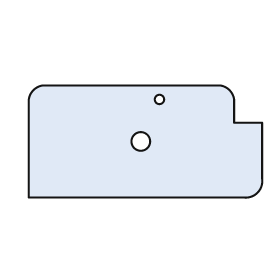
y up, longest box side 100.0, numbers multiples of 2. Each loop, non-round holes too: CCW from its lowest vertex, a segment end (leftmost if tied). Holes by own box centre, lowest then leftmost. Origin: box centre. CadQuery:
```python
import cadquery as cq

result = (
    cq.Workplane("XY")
    .moveTo(-50.0, -24.0)
    .lineTo(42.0, -24.0)
    .threePointArc((48.0, -22.0), (50.0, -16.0))
    .lineTo(50.0, 8.0)
    .lineTo(38.0, 8.0)
    .lineTo(38.0, 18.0)
    .threePointArc((36.0, 22.0), (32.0, 24.0))
    .lineTo(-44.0, 24.0)
    .threePointArc((-48.0, 22.0), (-50.0, 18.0))
    .close()
    .moveTo(-2.0, 0.0)
    .circle(4.0)
    .moveTo(6.0, 18.0)
    .circle(2.0)
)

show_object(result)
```